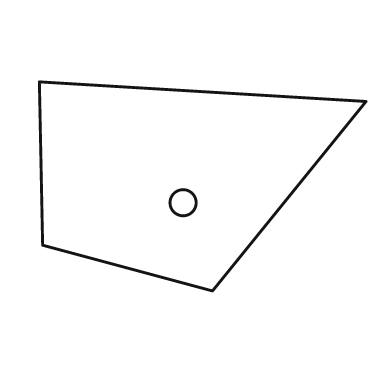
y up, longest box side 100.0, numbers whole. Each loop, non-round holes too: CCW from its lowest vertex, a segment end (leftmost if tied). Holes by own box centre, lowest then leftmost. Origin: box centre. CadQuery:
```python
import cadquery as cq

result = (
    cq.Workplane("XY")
    .moveTo(3.0, -32.0)
    .lineTo(50.0, 26.0)
    .lineTo(-50.0, 32.0)
    .lineTo(-49.0, -18.0)
    .close()
    .moveTo(-6.0, -5.0)
    .circle(4.0)
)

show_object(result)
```